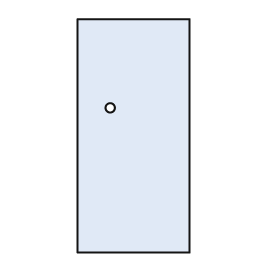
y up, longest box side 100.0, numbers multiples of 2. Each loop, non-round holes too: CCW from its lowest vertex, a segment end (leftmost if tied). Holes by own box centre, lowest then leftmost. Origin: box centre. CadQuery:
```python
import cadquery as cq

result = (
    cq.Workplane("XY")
    .moveTo(-24.0, -50.0)
    .lineTo(24.0, -50.0)
    .lineTo(24.0, 50.0)
    .lineTo(-24.0, 50.0)
    .close()
    .moveTo(-10.0, 12.0)
    .circle(2.0)
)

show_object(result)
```